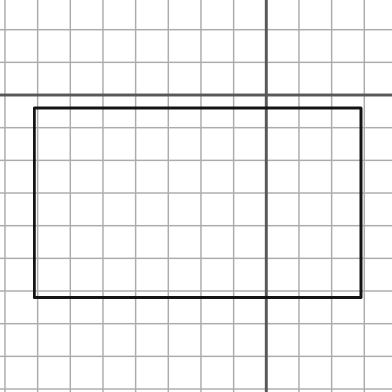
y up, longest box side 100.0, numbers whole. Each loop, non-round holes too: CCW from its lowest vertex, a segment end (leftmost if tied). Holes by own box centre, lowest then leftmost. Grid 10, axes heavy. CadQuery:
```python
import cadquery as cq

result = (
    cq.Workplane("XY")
    .moveTo(-71.0, -62.0)
    .lineTo(29.0, -62.0)
    .lineTo(29.0, -4.0)
    .lineTo(-71.0, -4.0)
    .close()
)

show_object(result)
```